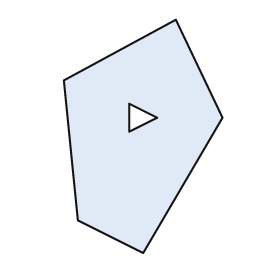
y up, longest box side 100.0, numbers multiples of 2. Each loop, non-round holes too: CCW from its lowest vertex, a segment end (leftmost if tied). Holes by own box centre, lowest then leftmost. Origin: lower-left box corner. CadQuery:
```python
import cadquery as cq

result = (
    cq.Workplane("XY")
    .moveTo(34.0, 0.0)
    .lineTo(68.0, 58.0)
    .lineTo(48.0, 100.0)
    .lineTo(0.0, 74.0)
    .lineTo(6.0, 14.0)
    .close()
    .moveTo(28.0, 52.0)
    .lineTo(40.0, 58.0)
    .lineTo(28.0, 64.0)
    .close()
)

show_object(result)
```